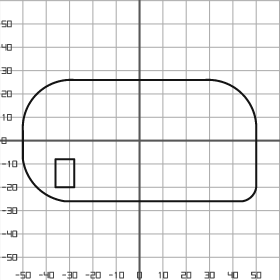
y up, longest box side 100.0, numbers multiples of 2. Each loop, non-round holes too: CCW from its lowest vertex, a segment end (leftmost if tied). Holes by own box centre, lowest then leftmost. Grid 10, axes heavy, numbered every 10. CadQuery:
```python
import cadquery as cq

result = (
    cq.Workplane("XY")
    .moveTo(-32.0, -26.0)
    .lineTo(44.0, -26.0)
    .threePointArc((48.0, -24.0), (50.0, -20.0))
    .lineTo(50.0, 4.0)
    .threePointArc((44.0, 20.0), (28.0, 26.0))
    .lineTo(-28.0, 26.0)
    .threePointArc((-44.0, 20.0), (-50.0, 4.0))
    .lineTo(-50.0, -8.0)
    .threePointArc((-44.0, -20.0), (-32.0, -26.0))
    .close()
    .moveTo(-36.0, -20.0)
    .lineTo(-28.0, -20.0)
    .lineTo(-28.0, -8.0)
    .lineTo(-36.0, -8.0)
    .close()
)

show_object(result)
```